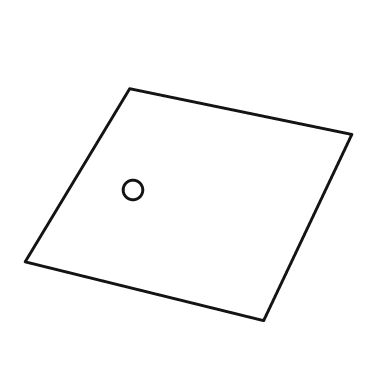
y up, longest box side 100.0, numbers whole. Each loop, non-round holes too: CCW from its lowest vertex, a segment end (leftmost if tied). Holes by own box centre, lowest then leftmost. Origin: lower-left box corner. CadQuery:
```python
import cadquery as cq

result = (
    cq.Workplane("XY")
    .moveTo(73.0, 0.0)
    .lineTo(100.0, 57.0)
    .lineTo(32.0, 71.0)
    .lineTo(0.0, 18.0)
    .close()
    .moveTo(33.0, 40.0)
    .circle(3.0)
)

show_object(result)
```